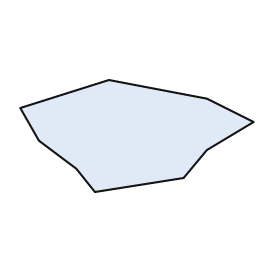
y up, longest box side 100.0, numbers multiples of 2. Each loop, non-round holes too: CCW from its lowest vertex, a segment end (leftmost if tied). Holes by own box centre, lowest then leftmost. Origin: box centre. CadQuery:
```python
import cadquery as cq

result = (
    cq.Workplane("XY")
    .moveTo(-18.0, -24.0)
    .lineTo(20.0, -18.0)
    .lineTo(30.0, -6.0)
    .lineTo(50.0, 6.0)
    .lineTo(30.0, 16.0)
    .lineTo(-12.0, 24.0)
    .lineTo(-50.0, 12.0)
    .lineTo(-42.0, -2.0)
    .lineTo(-26.0, -14.0)
    .close()
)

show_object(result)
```